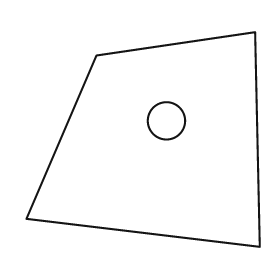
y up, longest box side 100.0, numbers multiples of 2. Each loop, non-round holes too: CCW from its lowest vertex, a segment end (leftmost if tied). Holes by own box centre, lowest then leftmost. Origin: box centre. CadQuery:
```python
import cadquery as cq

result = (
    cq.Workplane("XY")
    .moveTo(50.0, -46.0)
    .lineTo(48.0, 46.0)
    .lineTo(-20.0, 36.0)
    .lineTo(-50.0, -34.0)
    .close()
    .moveTo(10.0, 8.0)
    .circle(8.0)
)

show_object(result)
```